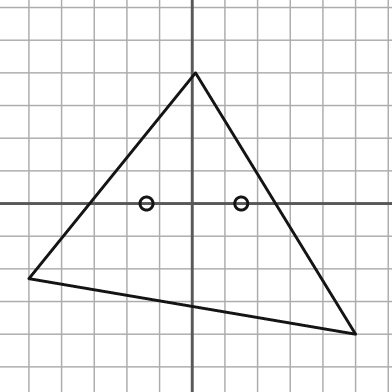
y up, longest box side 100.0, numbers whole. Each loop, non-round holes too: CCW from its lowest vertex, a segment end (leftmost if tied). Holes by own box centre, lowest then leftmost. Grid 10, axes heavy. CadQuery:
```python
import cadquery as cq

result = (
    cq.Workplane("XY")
    .moveTo(50.0, -40.0)
    .lineTo(1.0, 40.0)
    .lineTo(-50.0, -23.0)
    .close()
    .moveTo(-14.0, 0.0)
    .circle(2.0)
    .moveTo(15.0, 0.0)
    .circle(2.0)
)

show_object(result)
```